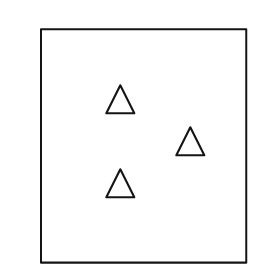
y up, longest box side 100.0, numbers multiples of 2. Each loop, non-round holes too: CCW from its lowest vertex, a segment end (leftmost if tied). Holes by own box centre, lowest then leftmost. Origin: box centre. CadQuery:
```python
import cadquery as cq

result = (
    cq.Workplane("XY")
    .moveTo(-44.0, -50.0)
    .lineTo(44.0, -50.0)
    .lineTo(44.0, 50.0)
    .lineTo(-44.0, 50.0)
    .close()
    .moveTo(-16.0, -22.0)
    .lineTo(-4.0, -22.0)
    .lineTo(-10.0, -10.0)
    .close()
    .moveTo(14.0, -4.0)
    .lineTo(26.0, -4.0)
    .lineTo(20.0, 8.0)
    .close()
    .moveTo(-16.0, 14.0)
    .lineTo(-4.0, 14.0)
    .lineTo(-10.0, 26.0)
    .close()
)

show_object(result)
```